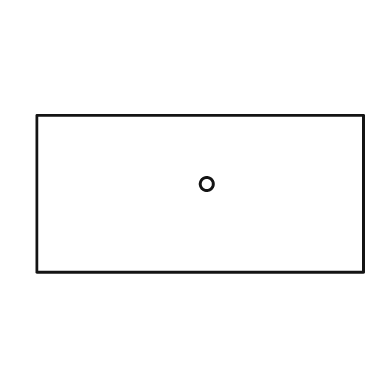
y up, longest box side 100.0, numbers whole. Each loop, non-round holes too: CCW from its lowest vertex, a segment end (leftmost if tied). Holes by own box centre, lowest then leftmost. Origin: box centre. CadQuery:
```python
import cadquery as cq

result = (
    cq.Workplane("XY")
    .moveTo(-50.0, -24.0)
    .lineTo(50.0, -24.0)
    .lineTo(50.0, 24.0)
    .lineTo(-50.0, 24.0)
    .close()
    .moveTo(2.0, 3.0)
    .circle(2.0)
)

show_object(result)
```